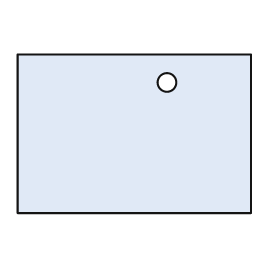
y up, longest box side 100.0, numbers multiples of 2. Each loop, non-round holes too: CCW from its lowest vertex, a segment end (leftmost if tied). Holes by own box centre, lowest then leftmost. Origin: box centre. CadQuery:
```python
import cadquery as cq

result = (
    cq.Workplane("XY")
    .moveTo(-50.0, -34.0)
    .lineTo(50.0, -34.0)
    .lineTo(50.0, 34.0)
    .lineTo(-50.0, 34.0)
    .close()
    .moveTo(14.0, 22.0)
    .circle(4.0)
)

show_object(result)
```